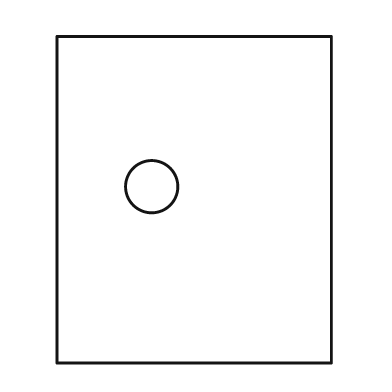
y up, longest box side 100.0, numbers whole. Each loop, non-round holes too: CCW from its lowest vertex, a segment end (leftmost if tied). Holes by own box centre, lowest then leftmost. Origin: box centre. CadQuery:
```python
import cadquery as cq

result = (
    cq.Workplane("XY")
    .moveTo(-42.0, -50.0)
    .lineTo(42.0, -50.0)
    .lineTo(42.0, 50.0)
    .lineTo(-42.0, 50.0)
    .close()
    .moveTo(-13.0, 4.0)
    .circle(8.0)
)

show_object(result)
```